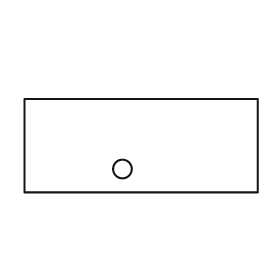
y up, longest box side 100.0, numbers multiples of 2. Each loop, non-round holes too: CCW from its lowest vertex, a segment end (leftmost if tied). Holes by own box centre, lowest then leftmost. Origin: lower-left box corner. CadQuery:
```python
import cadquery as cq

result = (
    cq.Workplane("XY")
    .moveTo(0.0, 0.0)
    .lineTo(100.0, 0.0)
    .lineTo(100.0, 40.0)
    .lineTo(0.0, 40.0)
    .close()
    .moveTo(42.0, 10.0)
    .circle(4.0)
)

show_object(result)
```